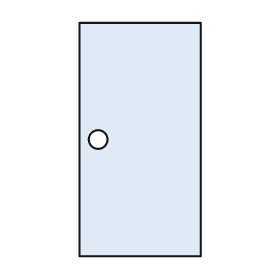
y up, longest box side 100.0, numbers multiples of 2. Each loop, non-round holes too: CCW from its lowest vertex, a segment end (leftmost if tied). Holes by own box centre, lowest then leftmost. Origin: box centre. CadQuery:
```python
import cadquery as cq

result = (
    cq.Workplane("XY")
    .moveTo(-26.0, -50.0)
    .lineTo(26.0, -50.0)
    .lineTo(26.0, 50.0)
    .lineTo(-26.0, 50.0)
    .close()
    .moveTo(-18.0, 0.0)
    .circle(4.0)
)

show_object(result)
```